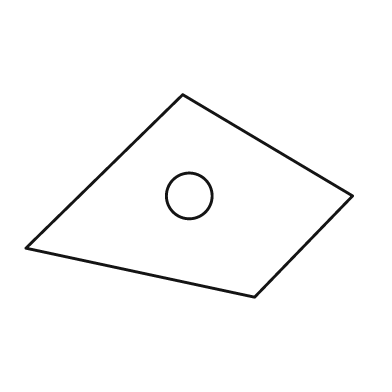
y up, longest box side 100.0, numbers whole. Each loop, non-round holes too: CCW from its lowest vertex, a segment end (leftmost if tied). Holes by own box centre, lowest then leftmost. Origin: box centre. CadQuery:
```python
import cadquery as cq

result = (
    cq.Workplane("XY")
    .moveTo(20.0, -31.0)
    .lineTo(50.0, 0.0)
    .lineTo(-2.0, 31.0)
    .lineTo(-50.0, -16.0)
    .close()
    .moveTo(0.0, 0.0)
    .circle(7.0)
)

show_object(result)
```